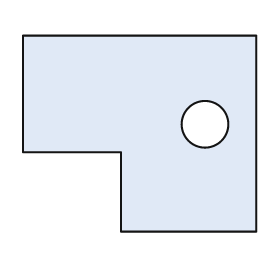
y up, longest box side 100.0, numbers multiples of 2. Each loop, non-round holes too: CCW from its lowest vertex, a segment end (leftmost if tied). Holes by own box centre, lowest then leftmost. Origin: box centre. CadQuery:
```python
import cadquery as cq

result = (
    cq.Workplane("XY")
    .moveTo(-8.0, -42.0)
    .lineTo(50.0, -42.0)
    .lineTo(50.0, 42.0)
    .lineTo(-50.0, 42.0)
    .lineTo(-50.0, -8.0)
    .lineTo(-8.0, -8.0)
    .close()
    .moveTo(28.0, 4.0)
    .circle(10.0)
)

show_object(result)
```